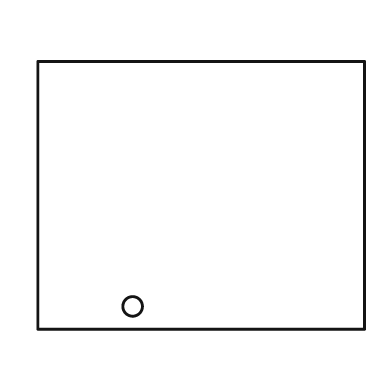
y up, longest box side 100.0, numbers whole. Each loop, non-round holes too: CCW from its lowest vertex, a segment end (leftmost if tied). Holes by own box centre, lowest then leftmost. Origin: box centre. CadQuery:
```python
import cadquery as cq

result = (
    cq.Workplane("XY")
    .moveTo(-50.0, -41.0)
    .lineTo(50.0, -41.0)
    .lineTo(50.0, 41.0)
    .lineTo(-50.0, 41.0)
    .close()
    .moveTo(-21.0, -34.0)
    .circle(3.0)
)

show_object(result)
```